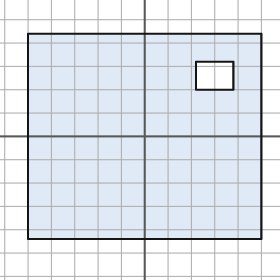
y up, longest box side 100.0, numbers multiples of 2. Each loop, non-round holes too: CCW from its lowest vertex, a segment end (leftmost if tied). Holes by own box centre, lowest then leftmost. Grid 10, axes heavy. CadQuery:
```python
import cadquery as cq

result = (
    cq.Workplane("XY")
    .moveTo(-50.0, -44.0)
    .lineTo(50.0, -44.0)
    .lineTo(50.0, 44.0)
    .lineTo(-50.0, 44.0)
    .close()
    .moveTo(22.0, 20.0)
    .lineTo(38.0, 20.0)
    .lineTo(38.0, 32.0)
    .lineTo(22.0, 32.0)
    .close()
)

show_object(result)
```